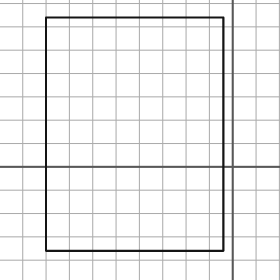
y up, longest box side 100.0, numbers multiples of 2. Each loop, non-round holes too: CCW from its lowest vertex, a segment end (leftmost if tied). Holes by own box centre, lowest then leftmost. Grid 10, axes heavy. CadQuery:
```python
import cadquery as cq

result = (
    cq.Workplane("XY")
    .moveTo(-80.0, -36.0)
    .lineTo(-4.0, -36.0)
    .lineTo(-4.0, 64.0)
    .lineTo(-80.0, 64.0)
    .close()
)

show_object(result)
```